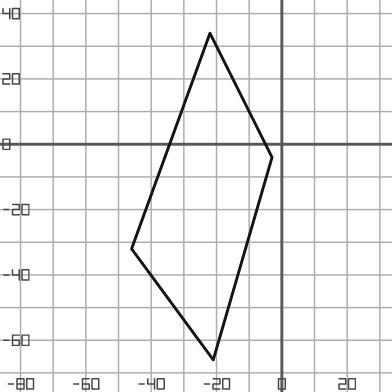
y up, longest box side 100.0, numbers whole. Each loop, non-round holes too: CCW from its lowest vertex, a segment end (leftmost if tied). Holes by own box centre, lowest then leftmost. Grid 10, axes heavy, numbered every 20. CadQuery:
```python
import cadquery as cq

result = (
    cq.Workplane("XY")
    .moveTo(-21.0, -66.0)
    .lineTo(-3.0, -4.0)
    .lineTo(-22.0, 34.0)
    .lineTo(-46.0, -32.0)
    .close()
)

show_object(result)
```